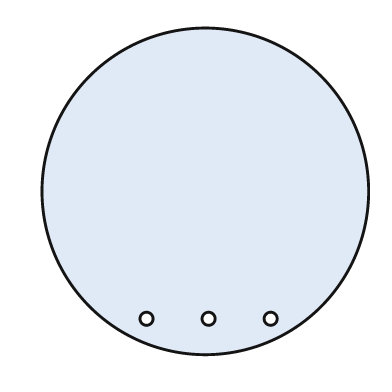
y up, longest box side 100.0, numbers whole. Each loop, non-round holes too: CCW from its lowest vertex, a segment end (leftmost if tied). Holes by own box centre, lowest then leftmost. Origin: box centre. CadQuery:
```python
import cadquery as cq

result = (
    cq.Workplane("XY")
    .moveTo(0.0, 0.0)
    .circle(50.0)
    .moveTo(-18.0, -39.0)
    .circle(2.0)
    .moveTo(1.0, -39.0)
    .circle(2.0)
    .moveTo(20.0, -39.0)
    .circle(2.0)
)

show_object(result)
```